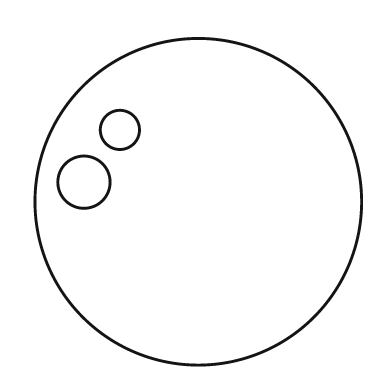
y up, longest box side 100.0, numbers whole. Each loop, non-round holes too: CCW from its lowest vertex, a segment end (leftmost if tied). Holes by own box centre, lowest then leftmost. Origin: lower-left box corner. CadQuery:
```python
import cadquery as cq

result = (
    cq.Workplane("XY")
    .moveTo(50.0, 50.0)
    .circle(50.0)
    .moveTo(15.0, 56.0)
    .circle(8.0)
    .moveTo(26.0, 72.0)
    .circle(6.0)
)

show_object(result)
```